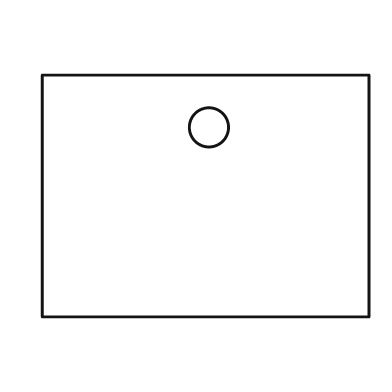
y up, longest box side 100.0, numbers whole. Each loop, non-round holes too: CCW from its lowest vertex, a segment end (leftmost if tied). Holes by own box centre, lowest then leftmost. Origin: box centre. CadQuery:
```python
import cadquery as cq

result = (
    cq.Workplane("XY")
    .moveTo(-50.0, -37.0)
    .lineTo(50.0, -37.0)
    .lineTo(50.0, 37.0)
    .lineTo(-50.0, 37.0)
    .close()
    .moveTo(1.0, 21.0)
    .circle(6.0)
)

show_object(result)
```